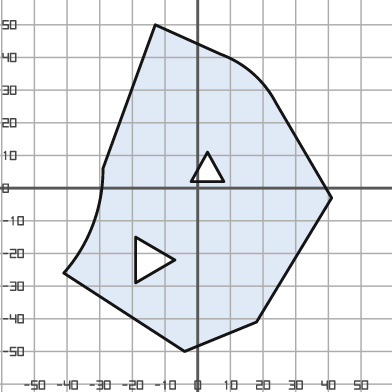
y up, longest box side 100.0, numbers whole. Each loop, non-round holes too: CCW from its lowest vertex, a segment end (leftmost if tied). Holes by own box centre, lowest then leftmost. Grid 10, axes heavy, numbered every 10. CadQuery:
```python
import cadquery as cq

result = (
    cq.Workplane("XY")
    .moveTo(-4.0, -50.0)
    .lineTo(18.0, -41.0)
    .lineTo(41.0, -3.0)
    .lineTo(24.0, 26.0)
    .threePointArc((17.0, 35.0), (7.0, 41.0))
    .lineTo(-13.0, 50.0)
    .lineTo(-29.0, 6.0)
    .threePointArc((-32.0, -11.0), (-41.0, -26.0))
    .close()
    .moveTo(-19.0, -29.0)
    .lineTo(-7.0, -22.0)
    .lineTo(-19.0, -15.0)
    .close()
    .moveTo(-2.0, 2.0)
    .lineTo(8.0, 2.0)
    .lineTo(3.0, 11.0)
    .close()
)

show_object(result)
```